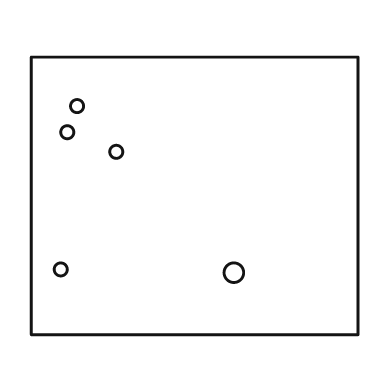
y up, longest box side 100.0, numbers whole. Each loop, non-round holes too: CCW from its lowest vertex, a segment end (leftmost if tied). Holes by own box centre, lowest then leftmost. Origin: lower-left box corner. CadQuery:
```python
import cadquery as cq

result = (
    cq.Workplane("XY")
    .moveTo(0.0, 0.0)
    .lineTo(100.0, 0.0)
    .lineTo(100.0, 85.0)
    .lineTo(0.0, 85.0)
    .close()
    .moveTo(62.0, 19.0)
    .circle(3.0)
    .moveTo(9.0, 20.0)
    .circle(2.0)
    .moveTo(26.0, 56.0)
    .circle(2.0)
    .moveTo(11.0, 62.0)
    .circle(2.0)
    .moveTo(14.0, 70.0)
    .circle(2.0)
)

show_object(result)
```